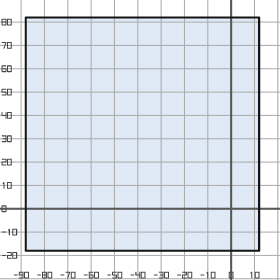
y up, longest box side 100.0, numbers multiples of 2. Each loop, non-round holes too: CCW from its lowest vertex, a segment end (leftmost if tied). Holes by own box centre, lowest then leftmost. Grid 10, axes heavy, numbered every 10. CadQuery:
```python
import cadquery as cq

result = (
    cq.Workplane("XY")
    .moveTo(-88.0, -18.0)
    .lineTo(12.0, -18.0)
    .lineTo(12.0, 82.0)
    .lineTo(-88.0, 82.0)
    .close()
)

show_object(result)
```